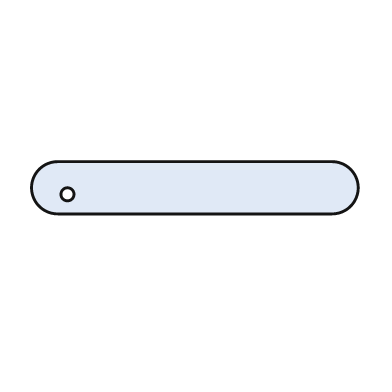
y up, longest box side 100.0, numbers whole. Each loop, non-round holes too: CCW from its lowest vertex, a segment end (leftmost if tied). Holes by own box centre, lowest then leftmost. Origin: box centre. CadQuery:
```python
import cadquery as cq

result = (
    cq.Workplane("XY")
    .moveTo(-42.0, -8.0)
    .lineTo(42.0, -8.0)
    .threePointArc((50.0, 0.0), (42.0, 8.0))
    .lineTo(-42.0, 8.0)
    .threePointArc((-50.0, 0.0), (-42.0, -8.0))
    .close()
    .moveTo(-39.0, -2.0)
    .circle(2.0)
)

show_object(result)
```